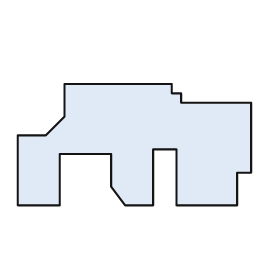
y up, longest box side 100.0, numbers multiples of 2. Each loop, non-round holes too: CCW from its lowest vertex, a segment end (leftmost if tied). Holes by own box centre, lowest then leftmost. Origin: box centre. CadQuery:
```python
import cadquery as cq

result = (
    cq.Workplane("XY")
    .moveTo(-50.0, -26.0)
    .lineTo(-32.0, -26.0)
    .lineTo(-32.0, -4.0)
    .lineTo(-10.0, -4.0)
    .lineTo(-10.0, -18.0)
    .lineTo(-4.0, -26.0)
    .lineTo(8.0, -26.0)
    .lineTo(8.0, -2.0)
    .lineTo(18.0, -2.0)
    .lineTo(18.0, -26.0)
    .lineTo(44.0, -26.0)
    .lineTo(44.0, -12.0)
    .lineTo(50.0, -12.0)
    .lineTo(50.0, 18.0)
    .lineTo(20.0, 18.0)
    .lineTo(20.0, 22.0)
    .lineTo(16.0, 22.0)
    .lineTo(16.0, 26.0)
    .lineTo(-30.0, 26.0)
    .lineTo(-30.0, 12.0)
    .lineTo(-38.0, 4.0)
    .lineTo(-50.0, 4.0)
    .close()
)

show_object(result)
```